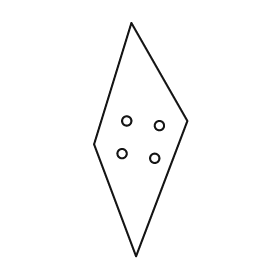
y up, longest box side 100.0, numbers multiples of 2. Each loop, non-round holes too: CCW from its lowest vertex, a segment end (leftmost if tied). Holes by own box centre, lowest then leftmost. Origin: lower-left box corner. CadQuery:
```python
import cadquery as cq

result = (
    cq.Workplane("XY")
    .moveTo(18.0, 0.0)
    .lineTo(40.0, 58.0)
    .lineTo(16.0, 100.0)
    .lineTo(0.0, 48.0)
    .close()
    .moveTo(26.0, 42.0)
    .circle(2.0)
    .moveTo(12.0, 44.0)
    .circle(2.0)
    .moveTo(28.0, 56.0)
    .circle(2.0)
    .moveTo(14.0, 58.0)
    .circle(2.0)
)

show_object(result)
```